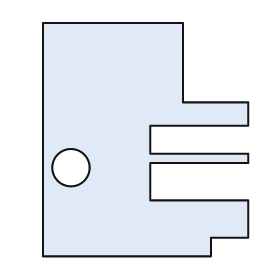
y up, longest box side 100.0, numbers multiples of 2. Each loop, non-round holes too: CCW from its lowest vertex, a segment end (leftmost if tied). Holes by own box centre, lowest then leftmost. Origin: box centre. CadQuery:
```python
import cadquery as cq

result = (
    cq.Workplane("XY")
    .moveTo(-44.0, -50.0)
    .lineTo(28.0, -50.0)
    .lineTo(28.0, -42.0)
    .lineTo(44.0, -42.0)
    .lineTo(44.0, -26.0)
    .lineTo(2.0, -26.0)
    .lineTo(2.0, -10.0)
    .lineTo(44.0, -10.0)
    .lineTo(44.0, -6.0)
    .lineTo(2.0, -6.0)
    .lineTo(2.0, 6.0)
    .lineTo(44.0, 6.0)
    .lineTo(44.0, 16.0)
    .lineTo(16.0, 16.0)
    .lineTo(16.0, 50.0)
    .lineTo(-44.0, 50.0)
    .close()
    .moveTo(-32.0, -12.0)
    .circle(8.0)
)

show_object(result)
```